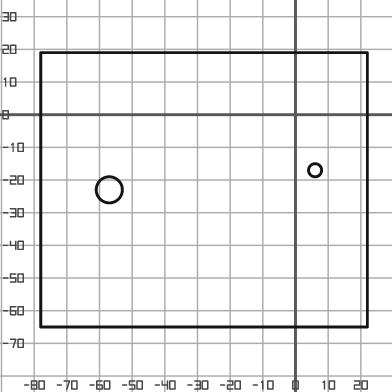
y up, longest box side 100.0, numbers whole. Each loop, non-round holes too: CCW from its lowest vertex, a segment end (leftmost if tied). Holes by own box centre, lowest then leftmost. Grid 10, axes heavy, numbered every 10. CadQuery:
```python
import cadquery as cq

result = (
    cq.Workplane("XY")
    .moveTo(-78.0, -65.0)
    .lineTo(22.0, -65.0)
    .lineTo(22.0, 19.0)
    .lineTo(-78.0, 19.0)
    .close()
    .moveTo(-57.0, -23.0)
    .circle(4.0)
    .moveTo(6.0, -17.0)
    .circle(2.0)
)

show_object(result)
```